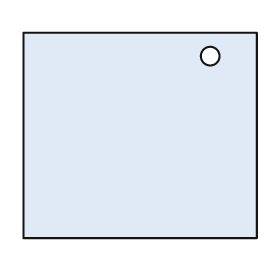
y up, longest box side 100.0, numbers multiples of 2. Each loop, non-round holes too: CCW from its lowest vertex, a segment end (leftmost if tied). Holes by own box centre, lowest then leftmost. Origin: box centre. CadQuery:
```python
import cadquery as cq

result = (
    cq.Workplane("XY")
    .moveTo(-50.0, -44.0)
    .lineTo(50.0, -44.0)
    .lineTo(50.0, 44.0)
    .lineTo(-50.0, 44.0)
    .close()
    .moveTo(30.0, 34.0)
    .circle(4.0)
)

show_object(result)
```